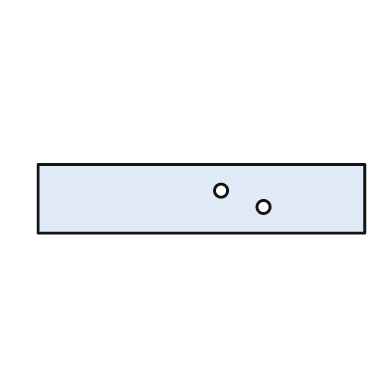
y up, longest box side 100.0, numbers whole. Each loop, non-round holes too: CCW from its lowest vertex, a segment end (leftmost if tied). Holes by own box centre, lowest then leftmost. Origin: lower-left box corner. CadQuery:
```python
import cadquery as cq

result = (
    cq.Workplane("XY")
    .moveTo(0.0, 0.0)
    .lineTo(100.0, 0.0)
    .lineTo(100.0, 21.0)
    .lineTo(0.0, 21.0)
    .close()
    .moveTo(69.0, 8.0)
    .circle(2.0)
    .moveTo(56.0, 13.0)
    .circle(2.0)
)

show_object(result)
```